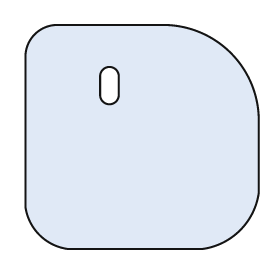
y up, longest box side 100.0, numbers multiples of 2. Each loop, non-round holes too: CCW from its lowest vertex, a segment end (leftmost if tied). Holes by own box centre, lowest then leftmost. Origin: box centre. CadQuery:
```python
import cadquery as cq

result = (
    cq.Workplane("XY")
    .moveTo(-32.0, -48.0)
    .lineTo(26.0, -48.0)
    .threePointArc((42.0, -40.0), (50.0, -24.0))
    .lineTo(50.0, 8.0)
    .threePointArc((38.0, 36.0), (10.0, 48.0))
    .lineTo(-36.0, 48.0)
    .threePointArc((-46.0, 44.0), (-50.0, 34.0))
    .lineTo(-50.0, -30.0)
    .threePointArc((-44.0, -42.0), (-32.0, -48.0))
    .close()
    .moveTo(-18.0, 18.0)
    .threePointArc((-14.0, 14.0), (-10.0, 18.0))
    .lineTo(-10.0, 26.0)
    .threePointArc((-14.0, 30.0), (-18.0, 26.0))
    .close()
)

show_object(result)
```